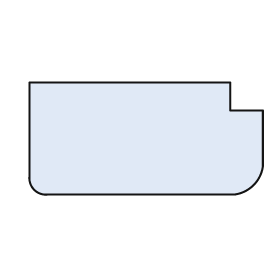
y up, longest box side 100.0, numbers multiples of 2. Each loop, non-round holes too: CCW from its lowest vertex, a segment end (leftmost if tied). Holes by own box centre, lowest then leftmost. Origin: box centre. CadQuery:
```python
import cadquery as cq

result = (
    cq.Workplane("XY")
    .moveTo(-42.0, -24.0)
    .lineTo(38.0, -24.0)
    .threePointArc((46.0, -20.0), (50.0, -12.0))
    .lineTo(50.0, 12.0)
    .lineTo(36.0, 12.0)
    .lineTo(36.0, 24.0)
    .lineTo(-50.0, 24.0)
    .lineTo(-50.0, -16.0)
    .threePointArc((-48.0, -22.0), (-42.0, -24.0))
    .close()
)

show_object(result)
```